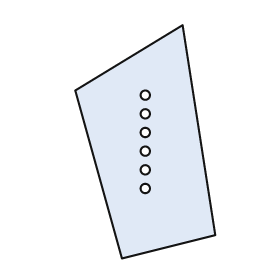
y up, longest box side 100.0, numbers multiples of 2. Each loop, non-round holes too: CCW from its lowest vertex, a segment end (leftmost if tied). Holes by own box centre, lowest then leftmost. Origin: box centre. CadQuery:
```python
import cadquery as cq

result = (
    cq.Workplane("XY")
    .moveTo(-10.0, -50.0)
    .lineTo(30.0, -40.0)
    .lineTo(16.0, 50.0)
    .lineTo(-30.0, 22.0)
    .close()
    .moveTo(0.0, -20.0)
    .circle(2.0)
    .moveTo(0.0, -12.0)
    .circle(2.0)
    .moveTo(0.0, -4.0)
    .circle(2.0)
    .moveTo(0.0, 4.0)
    .circle(2.0)
    .moveTo(0.0, 12.0)
    .circle(2.0)
    .moveTo(0.0, 20.0)
    .circle(2.0)
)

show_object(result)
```